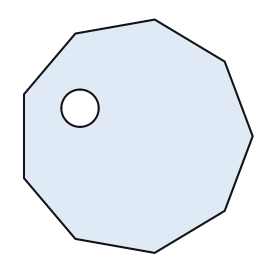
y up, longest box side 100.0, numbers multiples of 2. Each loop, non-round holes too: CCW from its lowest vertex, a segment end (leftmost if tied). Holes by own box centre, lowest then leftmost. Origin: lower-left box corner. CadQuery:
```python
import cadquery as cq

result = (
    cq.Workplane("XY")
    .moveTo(56.0, 0.0)
    .lineTo(86.0, 18.0)
    .lineTo(98.0, 50.0)
    .lineTo(86.0, 82.0)
    .lineTo(56.0, 100.0)
    .lineTo(22.0, 94.0)
    .lineTo(0.0, 68.0)
    .lineTo(0.0, 32.0)
    .lineTo(22.0, 6.0)
    .close()
    .moveTo(24.0, 62.0)
    .circle(8.0)
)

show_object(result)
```